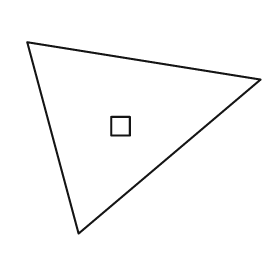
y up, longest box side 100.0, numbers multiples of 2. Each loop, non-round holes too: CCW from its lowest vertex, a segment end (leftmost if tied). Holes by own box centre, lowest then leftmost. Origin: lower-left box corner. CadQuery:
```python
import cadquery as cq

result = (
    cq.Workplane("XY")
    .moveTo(22.0, 0.0)
    .lineTo(100.0, 66.0)
    .lineTo(0.0, 82.0)
    .close()
    .moveTo(36.0, 42.0)
    .lineTo(44.0, 42.0)
    .lineTo(44.0, 50.0)
    .lineTo(36.0, 50.0)
    .close()
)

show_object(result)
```